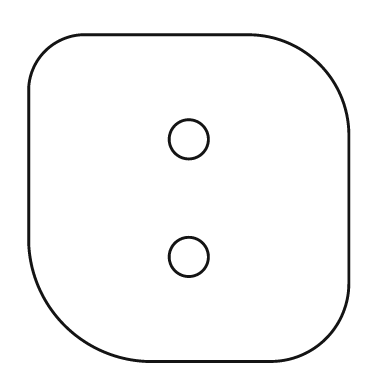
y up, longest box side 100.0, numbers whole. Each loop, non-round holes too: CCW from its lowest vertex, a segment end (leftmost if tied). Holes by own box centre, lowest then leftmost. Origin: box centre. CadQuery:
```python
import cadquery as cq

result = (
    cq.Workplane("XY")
    .moveTo(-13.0, -50.0)
    .lineTo(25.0, -50.0)
    .threePointArc((42.0, -43.0), (49.0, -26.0))
    .lineTo(49.0, 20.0)
    .threePointArc((40.0, 41.0), (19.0, 50.0))
    .lineTo(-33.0, 50.0)
    .threePointArc((-44.0, 45.0), (-49.0, 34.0))
    .lineTo(-49.0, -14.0)
    .threePointArc((-38.0, -39.0), (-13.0, -50.0))
    .close()
    .moveTo(0.0, -18.0)
    .circle(6.0)
    .moveTo(0.0, 18.0)
    .circle(6.0)
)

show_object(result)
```